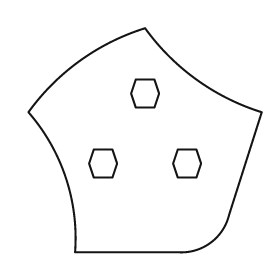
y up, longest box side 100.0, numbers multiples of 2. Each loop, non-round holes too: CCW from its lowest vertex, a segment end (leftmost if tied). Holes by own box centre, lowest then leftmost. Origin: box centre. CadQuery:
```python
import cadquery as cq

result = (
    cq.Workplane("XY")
    .moveTo(-30.0, -48.0)
    .lineTo(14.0, -48.0)
    .threePointArc((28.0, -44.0), (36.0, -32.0))
    .lineTo(50.0, 12.0)
    .threePointArc((22.0, 26.0), (0.0, 48.0))
    .threePointArc((-28.0, 34.0), (-50.0, 12.0))
    .threePointArc((-34.0, -16.0), (-30.0, -48.0))
    .close()
    .moveTo(-22.0, -16.0)
    .lineTo(-14.0, -16.0)
    .lineTo(-12.0, -10.0)
    .lineTo(-14.0, -4.0)
    .lineTo(-22.0, -4.0)
    .lineTo(-24.0, -10.0)
    .close()
    .moveTo(14.0, -16.0)
    .lineTo(22.0, -16.0)
    .lineTo(24.0, -10.0)
    .lineTo(22.0, -4.0)
    .lineTo(14.0, -4.0)
    .lineTo(12.0, -10.0)
    .close()
    .moveTo(-4.0, 14.0)
    .lineTo(4.0, 14.0)
    .lineTo(6.0, 20.0)
    .lineTo(4.0, 26.0)
    .lineTo(-4.0, 26.0)
    .lineTo(-6.0, 20.0)
    .close()
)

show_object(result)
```